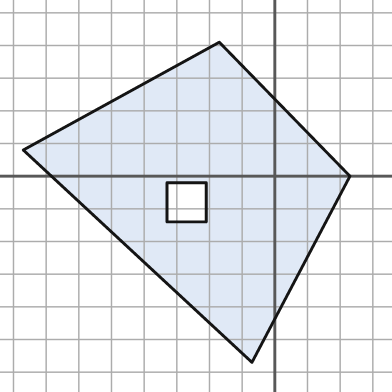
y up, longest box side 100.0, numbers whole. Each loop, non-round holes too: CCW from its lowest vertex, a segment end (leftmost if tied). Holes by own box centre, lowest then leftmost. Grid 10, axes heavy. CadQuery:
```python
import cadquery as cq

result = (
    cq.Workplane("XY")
    .moveTo(-7.0, -57.0)
    .lineTo(23.0, 0.0)
    .lineTo(-17.0, 41.0)
    .lineTo(-77.0, 8.0)
    .close()
    .moveTo(-33.0, -14.0)
    .lineTo(-21.0, -14.0)
    .lineTo(-21.0, -2.0)
    .lineTo(-33.0, -2.0)
    .close()
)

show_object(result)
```